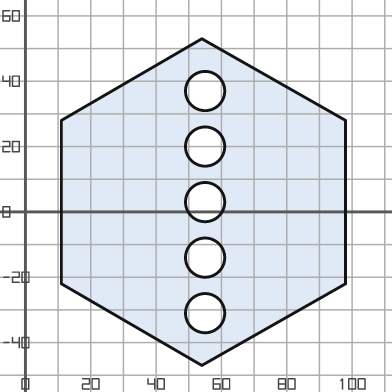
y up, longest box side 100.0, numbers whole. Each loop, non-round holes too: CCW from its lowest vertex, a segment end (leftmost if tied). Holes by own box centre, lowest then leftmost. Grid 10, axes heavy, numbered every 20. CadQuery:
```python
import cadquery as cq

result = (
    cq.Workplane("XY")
    .moveTo(54.0, -47.0)
    .lineTo(98.0, -22.0)
    .lineTo(98.0, 28.0)
    .lineTo(54.0, 53.0)
    .lineTo(11.0, 28.0)
    .lineTo(11.0, -22.0)
    .close()
    .moveTo(55.0, -31.0)
    .circle(6.0)
    .moveTo(55.0, -14.0)
    .circle(6.0)
    .moveTo(55.0, 3.0)
    .circle(6.0)
    .moveTo(55.0, 20.0)
    .circle(6.0)
    .moveTo(55.0, 37.0)
    .circle(6.0)
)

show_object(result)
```